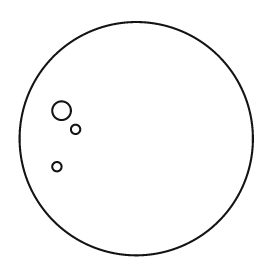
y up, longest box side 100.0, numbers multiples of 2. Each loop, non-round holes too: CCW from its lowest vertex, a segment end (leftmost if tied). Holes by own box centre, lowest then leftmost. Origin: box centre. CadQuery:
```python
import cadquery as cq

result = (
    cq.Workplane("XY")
    .moveTo(0.0, 0.0)
    .circle(50.0)
    .moveTo(-34.0, -12.0)
    .circle(2.0)
    .moveTo(-26.0, 4.0)
    .circle(2.0)
    .moveTo(-32.0, 12.0)
    .circle(4.0)
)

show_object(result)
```